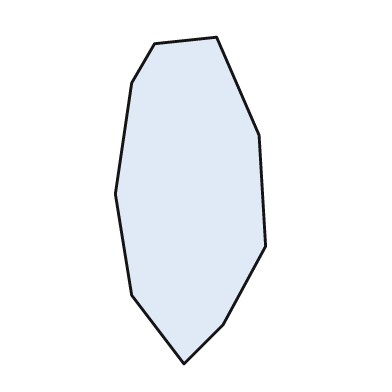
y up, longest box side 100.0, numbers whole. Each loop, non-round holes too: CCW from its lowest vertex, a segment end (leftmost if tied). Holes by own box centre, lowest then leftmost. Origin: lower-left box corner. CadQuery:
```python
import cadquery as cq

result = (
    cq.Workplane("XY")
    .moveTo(21.0, 0.0)
    .lineTo(33.0, 12.0)
    .lineTo(46.0, 36.0)
    .lineTo(44.0, 70.0)
    .lineTo(31.0, 100.0)
    .lineTo(12.0, 98.0)
    .lineTo(5.0, 86.0)
    .lineTo(0.0, 52.0)
    .lineTo(5.0, 21.0)
    .close()
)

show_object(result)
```